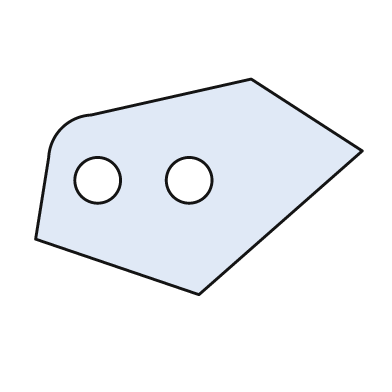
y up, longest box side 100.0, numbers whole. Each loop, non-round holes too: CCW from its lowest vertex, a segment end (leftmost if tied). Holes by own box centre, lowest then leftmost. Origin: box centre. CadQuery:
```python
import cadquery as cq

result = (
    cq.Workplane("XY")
    .moveTo(0.0, -33.0)
    .lineTo(50.0, 11.0)
    .lineTo(16.0, 33.0)
    .lineTo(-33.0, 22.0)
    .threePointArc((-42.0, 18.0), (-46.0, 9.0))
    .lineTo(-50.0, -16.0)
    .close()
    .moveTo(-31.0, 2.0)
    .circle(7.0)
    .moveTo(-3.0, 2.0)
    .circle(7.0)
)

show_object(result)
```